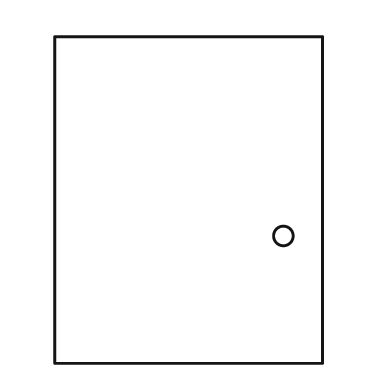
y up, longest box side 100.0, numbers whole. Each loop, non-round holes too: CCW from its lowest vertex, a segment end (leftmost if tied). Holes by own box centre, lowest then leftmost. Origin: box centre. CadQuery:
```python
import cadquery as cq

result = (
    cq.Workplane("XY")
    .moveTo(-41.0, -50.0)
    .lineTo(41.0, -50.0)
    .lineTo(41.0, 50.0)
    .lineTo(-41.0, 50.0)
    .close()
    .moveTo(29.0, -11.0)
    .circle(3.0)
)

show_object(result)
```